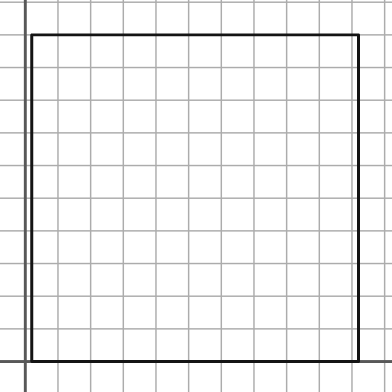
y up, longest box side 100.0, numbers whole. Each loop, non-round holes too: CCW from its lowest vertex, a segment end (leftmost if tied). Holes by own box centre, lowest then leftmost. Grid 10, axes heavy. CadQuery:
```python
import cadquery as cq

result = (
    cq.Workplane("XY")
    .moveTo(2.0, 0.0)
    .lineTo(102.0, 0.0)
    .lineTo(102.0, 100.0)
    .lineTo(2.0, 100.0)
    .close()
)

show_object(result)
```